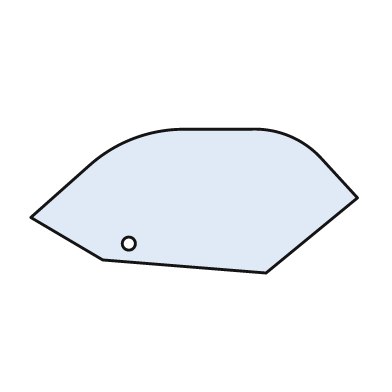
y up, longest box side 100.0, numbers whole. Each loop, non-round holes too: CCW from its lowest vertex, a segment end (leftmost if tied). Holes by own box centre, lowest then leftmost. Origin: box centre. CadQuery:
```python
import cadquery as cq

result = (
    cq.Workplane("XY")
    .moveTo(22.0, -22.0)
    .lineTo(50.0, 1.0)
    .lineTo(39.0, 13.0)
    .threePointArc((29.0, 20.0), (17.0, 22.0))
    .lineTo(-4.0, 22.0)
    .threePointArc((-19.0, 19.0), (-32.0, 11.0))
    .lineTo(-50.0, -5.0)
    .lineTo(-28.0, -18.0)
    .close()
    .moveTo(-20.0, -13.0)
    .circle(2.0)
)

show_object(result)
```